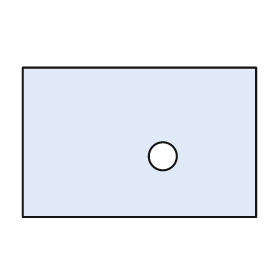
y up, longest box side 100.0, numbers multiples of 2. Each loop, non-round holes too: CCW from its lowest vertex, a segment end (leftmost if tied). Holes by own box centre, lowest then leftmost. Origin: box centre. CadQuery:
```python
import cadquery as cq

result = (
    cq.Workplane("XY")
    .moveTo(-50.0, -32.0)
    .lineTo(50.0, -32.0)
    .lineTo(50.0, 32.0)
    .lineTo(-50.0, 32.0)
    .close()
    .moveTo(10.0, -6.0)
    .circle(6.0)
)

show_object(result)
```